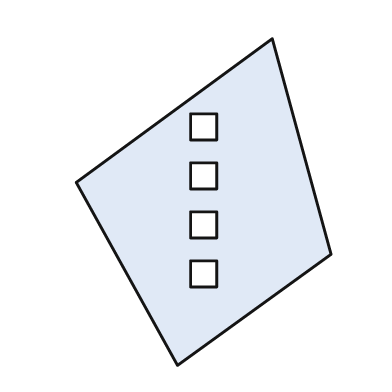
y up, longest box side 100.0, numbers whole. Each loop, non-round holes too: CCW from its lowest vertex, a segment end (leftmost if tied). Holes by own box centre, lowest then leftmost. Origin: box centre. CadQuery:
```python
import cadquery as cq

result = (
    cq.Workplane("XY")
    .moveTo(-8.0, -50.0)
    .lineTo(39.0, -16.0)
    .lineTo(21.0, 50.0)
    .lineTo(-39.0, 6.0)
    .close()
    .moveTo(-4.0, -26.0)
    .lineTo(4.0, -26.0)
    .lineTo(4.0, -18.0)
    .lineTo(-4.0, -18.0)
    .close()
    .moveTo(-4.0, -11.0)
    .lineTo(4.0, -11.0)
    .lineTo(4.0, -3.0)
    .lineTo(-4.0, -3.0)
    .close()
    .moveTo(-4.0, 4.0)
    .lineTo(4.0, 4.0)
    .lineTo(4.0, 12.0)
    .lineTo(-4.0, 12.0)
    .close()
    .moveTo(-4.0, 19.0)
    .lineTo(4.0, 19.0)
    .lineTo(4.0, 27.0)
    .lineTo(-4.0, 27.0)
    .close()
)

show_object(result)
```